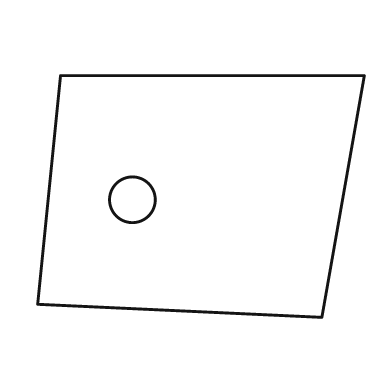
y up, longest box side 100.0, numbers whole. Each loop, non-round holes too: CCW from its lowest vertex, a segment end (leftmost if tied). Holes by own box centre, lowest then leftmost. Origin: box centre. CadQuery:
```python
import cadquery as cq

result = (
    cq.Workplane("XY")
    .moveTo(37.0, -37.0)
    .lineTo(50.0, 37.0)
    .lineTo(-43.0, 37.0)
    .lineTo(-50.0, -33.0)
    .close()
    .moveTo(-21.0, -1.0)
    .circle(7.0)
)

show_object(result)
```